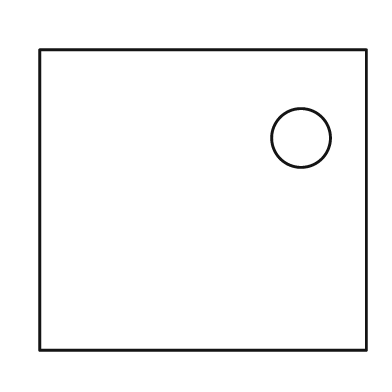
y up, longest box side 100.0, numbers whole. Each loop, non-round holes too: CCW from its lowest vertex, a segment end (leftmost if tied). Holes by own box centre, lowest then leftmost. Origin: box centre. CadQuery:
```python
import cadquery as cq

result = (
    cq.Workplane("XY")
    .moveTo(-50.0, -46.0)
    .lineTo(50.0, -46.0)
    .lineTo(50.0, 46.0)
    .lineTo(-50.0, 46.0)
    .close()
    .moveTo(30.0, 19.0)
    .circle(9.0)
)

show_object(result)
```